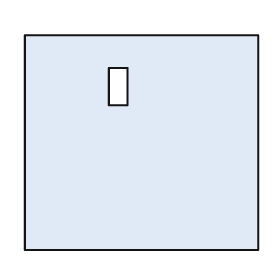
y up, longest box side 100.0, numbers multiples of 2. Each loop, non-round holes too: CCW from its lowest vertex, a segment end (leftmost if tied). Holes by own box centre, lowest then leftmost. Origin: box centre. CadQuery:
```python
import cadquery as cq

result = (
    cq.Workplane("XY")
    .moveTo(-50.0, -46.0)
    .lineTo(50.0, -46.0)
    .lineTo(50.0, 46.0)
    .lineTo(-50.0, 46.0)
    .close()
    .moveTo(-14.0, 16.0)
    .lineTo(-6.0, 16.0)
    .lineTo(-6.0, 32.0)
    .lineTo(-14.0, 32.0)
    .close()
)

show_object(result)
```